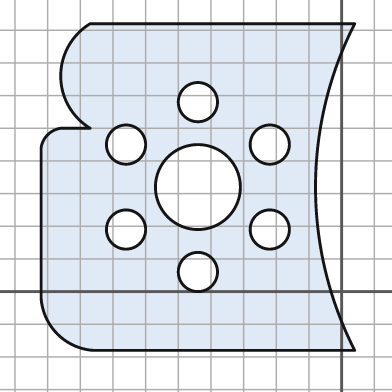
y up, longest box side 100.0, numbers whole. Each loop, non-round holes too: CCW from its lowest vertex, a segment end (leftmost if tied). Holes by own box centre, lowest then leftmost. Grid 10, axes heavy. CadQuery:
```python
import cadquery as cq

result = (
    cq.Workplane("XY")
    .moveTo(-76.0, -18.0)
    .lineTo(4.0, -18.0)
    .threePointArc((-8.0, 32.0), (4.0, 82.0))
    .lineTo(-77.0, 82.0)
    .threePointArc((-86.0, 66.0), (-77.0, 50.0))
    .lineTo(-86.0, 50.0)
    .threePointArc((-90.0, 48.0), (-92.0, 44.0))
    .lineTo(-92.0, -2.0)
    .threePointArc((-87.0, -13.0), (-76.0, -18.0))
    .close()
    .moveTo(-44.0, 6.0)
    .circle(6.0)
    .moveTo(-66.0, 19.0)
    .circle(6.0)
    .moveTo(-22.0, 19.0)
    .circle(6.0)
    .moveTo(-44.0, 32.0)
    .circle(13.0)
    .moveTo(-66.0, 45.0)
    .circle(6.0)
    .moveTo(-22.0, 45.0)
    .circle(6.0)
    .moveTo(-44.0, 58.0)
    .circle(6.0)
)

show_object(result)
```